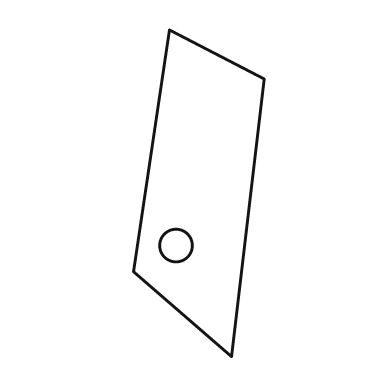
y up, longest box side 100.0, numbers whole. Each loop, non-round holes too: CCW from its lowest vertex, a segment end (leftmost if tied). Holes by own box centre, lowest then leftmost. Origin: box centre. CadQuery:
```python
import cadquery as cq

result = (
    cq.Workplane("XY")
    .moveTo(10.0, -50.0)
    .lineTo(20.0, 35.0)
    .lineTo(-9.0, 50.0)
    .lineTo(-20.0, -24.0)
    .close()
    .moveTo(-7.0, -16.0)
    .circle(5.0)
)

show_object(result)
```